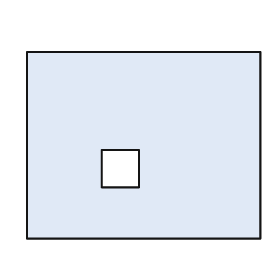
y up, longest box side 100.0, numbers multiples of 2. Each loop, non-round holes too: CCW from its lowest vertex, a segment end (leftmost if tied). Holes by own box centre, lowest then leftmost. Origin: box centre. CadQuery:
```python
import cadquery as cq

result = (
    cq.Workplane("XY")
    .moveTo(-50.0, -40.0)
    .lineTo(50.0, -40.0)
    .lineTo(50.0, 40.0)
    .lineTo(-50.0, 40.0)
    .close()
    .moveTo(-18.0, -18.0)
    .lineTo(-2.0, -18.0)
    .lineTo(-2.0, -2.0)
    .lineTo(-18.0, -2.0)
    .close()
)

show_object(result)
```